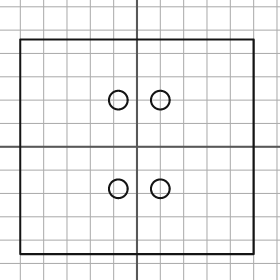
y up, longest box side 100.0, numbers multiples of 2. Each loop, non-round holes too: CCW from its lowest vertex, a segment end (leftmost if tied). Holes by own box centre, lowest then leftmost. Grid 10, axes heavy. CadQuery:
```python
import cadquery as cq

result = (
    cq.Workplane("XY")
    .moveTo(-50.0, -46.0)
    .lineTo(50.0, -46.0)
    .lineTo(50.0, 46.0)
    .lineTo(-50.0, 46.0)
    .close()
    .moveTo(-8.0, -18.0)
    .circle(4.0)
    .moveTo(10.0, -18.0)
    .circle(4.0)
    .moveTo(-8.0, 20.0)
    .circle(4.0)
    .moveTo(10.0, 20.0)
    .circle(4.0)
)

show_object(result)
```